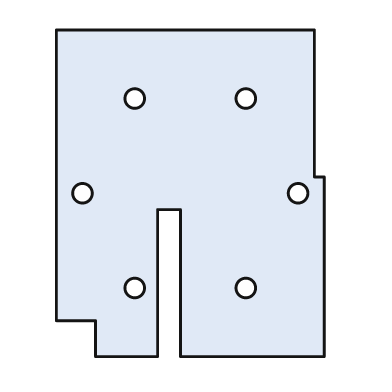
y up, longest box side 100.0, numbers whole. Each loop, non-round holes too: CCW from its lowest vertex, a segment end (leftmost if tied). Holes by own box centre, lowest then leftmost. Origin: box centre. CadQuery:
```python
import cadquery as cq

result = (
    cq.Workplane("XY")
    .moveTo(-29.0, -50.0)
    .lineTo(-10.0, -50.0)
    .lineTo(-10.0, -5.0)
    .lineTo(-3.0, -5.0)
    .lineTo(-3.0, -50.0)
    .lineTo(41.0, -50.0)
    .lineTo(41.0, 5.0)
    .lineTo(38.0, 5.0)
    .lineTo(38.0, 50.0)
    .lineTo(-41.0, 50.0)
    .lineTo(-41.0, -39.0)
    .lineTo(-29.0, -39.0)
    .close()
    .moveTo(-17.0, -29.0)
    .circle(3.0)
    .moveTo(17.0, -29.0)
    .circle(3.0)
    .moveTo(-33.0, 0.0)
    .circle(3.0)
    .moveTo(33.0, 0.0)
    .circle(3.0)
    .moveTo(-17.0, 29.0)
    .circle(3.0)
    .moveTo(17.0, 29.0)
    .circle(3.0)
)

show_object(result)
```